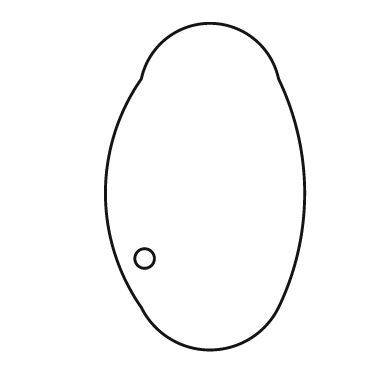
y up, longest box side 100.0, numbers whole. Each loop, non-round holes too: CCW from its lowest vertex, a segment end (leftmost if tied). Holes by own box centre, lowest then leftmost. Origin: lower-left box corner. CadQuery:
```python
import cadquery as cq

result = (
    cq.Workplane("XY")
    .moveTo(11.0, 13.0)
    .threePointArc((32.0, 0.0), (53.0, 13.0))
    .threePointArc((61.0, 48.0), (53.0, 83.0))
    .threePointArc((32.0, 100.0), (11.0, 83.0))
    .threePointArc((0.0, 48.0), (11.0, 13.0))
    .close()
    .moveTo(12.0, 28.0)
    .circle(3.0)
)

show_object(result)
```